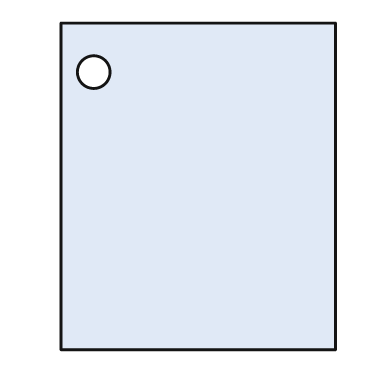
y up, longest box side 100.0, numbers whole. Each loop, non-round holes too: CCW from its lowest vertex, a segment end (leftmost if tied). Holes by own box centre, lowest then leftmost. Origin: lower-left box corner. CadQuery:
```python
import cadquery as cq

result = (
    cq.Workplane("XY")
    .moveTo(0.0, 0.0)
    .lineTo(84.0, 0.0)
    .lineTo(84.0, 100.0)
    .lineTo(0.0, 100.0)
    .close()
    .moveTo(10.0, 85.0)
    .circle(5.0)
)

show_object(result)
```